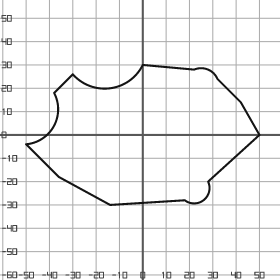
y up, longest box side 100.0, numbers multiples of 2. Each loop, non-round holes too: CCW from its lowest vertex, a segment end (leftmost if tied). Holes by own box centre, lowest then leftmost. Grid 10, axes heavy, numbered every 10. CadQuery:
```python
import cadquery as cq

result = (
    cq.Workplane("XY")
    .moveTo(-14.0, -30.0)
    .lineTo(18.0, -28.0)
    .threePointArc((26.0, -28.0), (28.0, -20.0))
    .lineTo(50.0, 0.0)
    .lineTo(42.0, 14.0)
    .lineTo(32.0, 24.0)
    .threePointArc((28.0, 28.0), (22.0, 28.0))
    .lineTo(0.0, 30.0)
    .threePointArc((-14.0, 20.0), (-30.0, 26.0))
    .lineTo(-38.0, 18.0)
    .threePointArc((-38.0, 4.0), (-50.0, -4.0))
    .lineTo(-36.0, -18.0)
    .close()
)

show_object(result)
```